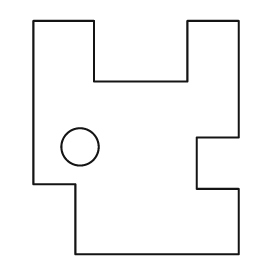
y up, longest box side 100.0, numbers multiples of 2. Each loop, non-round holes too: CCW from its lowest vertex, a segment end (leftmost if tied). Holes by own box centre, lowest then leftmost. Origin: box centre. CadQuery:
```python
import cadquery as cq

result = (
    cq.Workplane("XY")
    .moveTo(-26.0, -50.0)
    .lineTo(44.0, -50.0)
    .lineTo(44.0, -22.0)
    .lineTo(26.0, -22.0)
    .lineTo(26.0, 0.0)
    .lineTo(44.0, 0.0)
    .lineTo(44.0, 50.0)
    .lineTo(22.0, 50.0)
    .lineTo(22.0, 24.0)
    .lineTo(-18.0, 24.0)
    .lineTo(-18.0, 50.0)
    .lineTo(-44.0, 50.0)
    .lineTo(-44.0, -20.0)
    .lineTo(-26.0, -20.0)
    .close()
    .moveTo(-24.0, -4.0)
    .circle(8.0)
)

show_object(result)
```